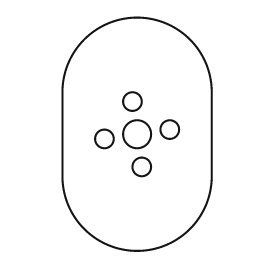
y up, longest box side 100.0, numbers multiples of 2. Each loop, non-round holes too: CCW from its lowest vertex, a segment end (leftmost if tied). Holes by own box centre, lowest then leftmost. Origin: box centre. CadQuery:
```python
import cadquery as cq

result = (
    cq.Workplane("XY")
    .moveTo(-32.0, -18.0)
    .threePointArc((0.0, -50.0), (32.0, -18.0))
    .lineTo(32.0, 18.0)
    .threePointArc((0.0, 50.0), (-32.0, 18.0))
    .close()
    .moveTo(2.0, -14.0)
    .circle(4.0)
    .moveTo(-14.0, -2.0)
    .circle(4.0)
    .moveTo(0.0, 0.0)
    .circle(6.0)
    .moveTo(14.0, 2.0)
    .circle(4.0)
    .moveTo(-2.0, 14.0)
    .circle(4.0)
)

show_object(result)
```